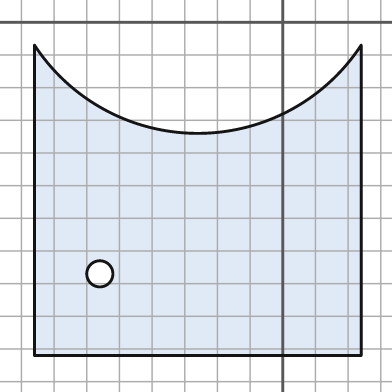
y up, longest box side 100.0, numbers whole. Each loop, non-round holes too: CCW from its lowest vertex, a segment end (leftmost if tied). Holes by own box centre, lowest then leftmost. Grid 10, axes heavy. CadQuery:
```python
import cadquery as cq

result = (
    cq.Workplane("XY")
    .moveTo(-76.0, -102.0)
    .lineTo(24.0, -102.0)
    .lineTo(24.0, -7.0)
    .threePointArc((-26.0, -34.0), (-76.0, -7.0))
    .close()
    .moveTo(-56.0, -77.0)
    .circle(4.0)
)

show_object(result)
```